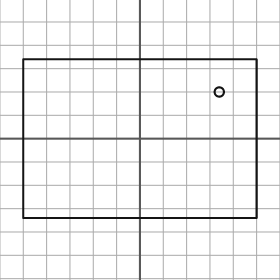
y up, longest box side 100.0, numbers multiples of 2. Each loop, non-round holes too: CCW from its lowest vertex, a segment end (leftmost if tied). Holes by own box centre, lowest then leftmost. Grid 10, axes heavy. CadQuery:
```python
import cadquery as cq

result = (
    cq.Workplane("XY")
    .moveTo(-50.0, -34.0)
    .lineTo(50.0, -34.0)
    .lineTo(50.0, 34.0)
    .lineTo(-50.0, 34.0)
    .close()
    .moveTo(34.0, 20.0)
    .circle(2.0)
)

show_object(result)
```